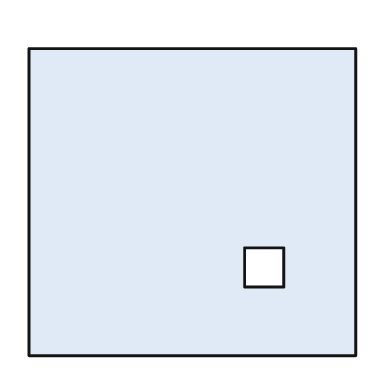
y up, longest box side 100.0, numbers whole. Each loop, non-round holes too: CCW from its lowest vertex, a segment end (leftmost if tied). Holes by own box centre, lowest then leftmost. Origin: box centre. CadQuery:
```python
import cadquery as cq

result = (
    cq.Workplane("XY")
    .moveTo(-50.0, -47.0)
    .lineTo(50.0, -47.0)
    .lineTo(50.0, 47.0)
    .lineTo(-50.0, 47.0)
    .close()
    .moveTo(16.0, -26.0)
    .lineTo(28.0, -26.0)
    .lineTo(28.0, -14.0)
    .lineTo(16.0, -14.0)
    .close()
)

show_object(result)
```